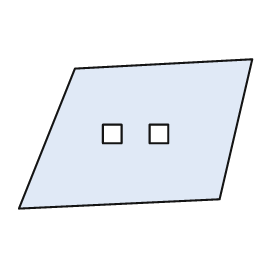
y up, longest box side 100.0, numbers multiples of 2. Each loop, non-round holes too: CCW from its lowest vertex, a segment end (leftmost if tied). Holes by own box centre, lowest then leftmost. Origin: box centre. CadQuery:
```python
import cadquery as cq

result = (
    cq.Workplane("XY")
    .moveTo(-50.0, -32.0)
    .lineTo(36.0, -28.0)
    .lineTo(50.0, 32.0)
    .lineTo(-26.0, 28.0)
    .close()
    .moveTo(-14.0, -4.0)
    .lineTo(-6.0, -4.0)
    .lineTo(-6.0, 4.0)
    .lineTo(-14.0, 4.0)
    .close()
    .moveTo(6.0, -4.0)
    .lineTo(14.0, -4.0)
    .lineTo(14.0, 4.0)
    .lineTo(6.0, 4.0)
    .close()
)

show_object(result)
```